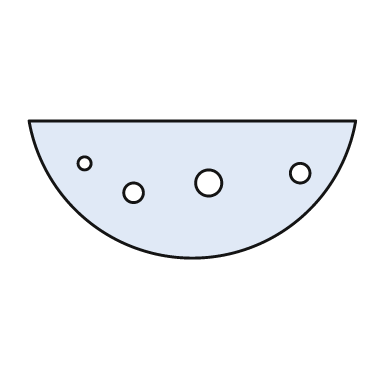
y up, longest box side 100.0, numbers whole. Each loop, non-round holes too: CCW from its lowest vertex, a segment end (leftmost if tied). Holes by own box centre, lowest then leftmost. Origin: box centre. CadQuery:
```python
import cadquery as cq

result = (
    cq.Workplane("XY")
    .moveTo(-50.0, 21.0)
    .threePointArc((0.0, -21.0), (50.0, 21.0))
    .close()
    .moveTo(-18.0, -1.0)
    .circle(3.0)
    .moveTo(5.0, 2.0)
    .circle(4.0)
    .moveTo(33.0, 5.0)
    .circle(3.0)
    .moveTo(-33.0, 8.0)
    .circle(2.0)
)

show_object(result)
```